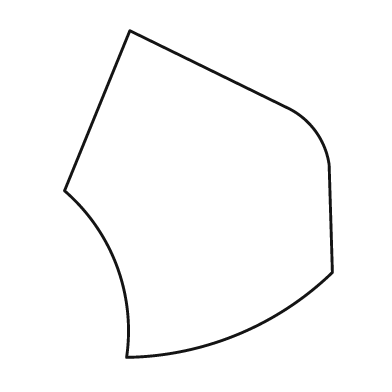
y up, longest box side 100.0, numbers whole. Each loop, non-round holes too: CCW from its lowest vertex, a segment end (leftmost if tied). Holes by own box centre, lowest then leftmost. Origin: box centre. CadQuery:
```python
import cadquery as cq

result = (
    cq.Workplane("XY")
    .moveTo(-22.0, -50.0)
    .threePointArc((12.0, -43.0), (41.0, -24.0))
    .lineTo(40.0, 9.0)
    .threePointArc((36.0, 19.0), (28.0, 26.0))
    .lineTo(-21.0, 50.0)
    .lineTo(-41.0, 1.0)
    .threePointArc((-25.0, -22.0), (-22.0, -50.0))
    .close()
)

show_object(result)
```